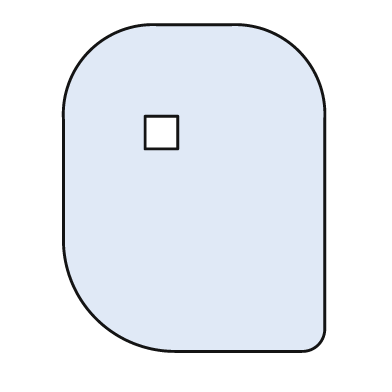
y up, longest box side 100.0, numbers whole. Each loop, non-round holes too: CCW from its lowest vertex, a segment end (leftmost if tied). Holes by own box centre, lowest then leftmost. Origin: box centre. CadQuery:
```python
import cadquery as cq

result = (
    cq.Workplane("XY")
    .moveTo(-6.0, -50.0)
    .lineTo(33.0, -50.0)
    .threePointArc((38.0, -48.0), (40.0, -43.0))
    .lineTo(40.0, 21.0)
    .threePointArc((32.0, 42.0), (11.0, 50.0))
    .lineTo(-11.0, 50.0)
    .threePointArc((-32.0, 42.0), (-40.0, 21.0))
    .lineTo(-40.0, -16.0)
    .threePointArc((-30.0, -40.0), (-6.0, -50.0))
    .close()
    .moveTo(-15.0, 12.0)
    .lineTo(-5.0, 12.0)
    .lineTo(-5.0, 22.0)
    .lineTo(-15.0, 22.0)
    .close()
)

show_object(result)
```